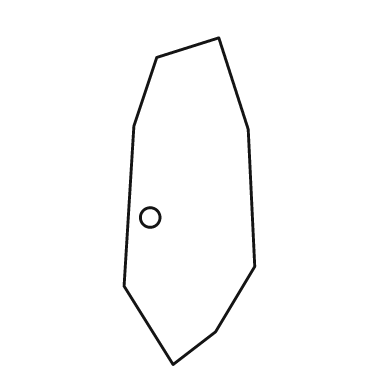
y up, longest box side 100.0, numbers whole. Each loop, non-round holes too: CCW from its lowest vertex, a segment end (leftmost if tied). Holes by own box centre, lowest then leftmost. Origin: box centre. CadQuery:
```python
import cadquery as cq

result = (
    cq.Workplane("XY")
    .moveTo(-5.0, -50.0)
    .lineTo(8.0, -40.0)
    .lineTo(20.0, -20.0)
    .lineTo(18.0, 22.0)
    .lineTo(9.0, 50.0)
    .lineTo(-10.0, 44.0)
    .lineTo(-17.0, 23.0)
    .lineTo(-20.0, -26.0)
    .close()
    .moveTo(-12.0, -5.0)
    .circle(3.0)
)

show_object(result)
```